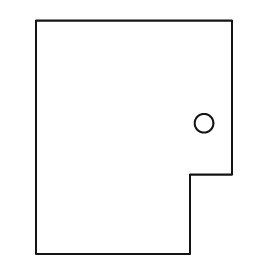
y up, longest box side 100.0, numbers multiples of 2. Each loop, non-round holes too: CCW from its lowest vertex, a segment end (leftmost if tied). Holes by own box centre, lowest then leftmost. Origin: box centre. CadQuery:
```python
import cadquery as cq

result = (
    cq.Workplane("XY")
    .moveTo(-42.0, -50.0)
    .lineTo(24.0, -50.0)
    .lineTo(24.0, -16.0)
    .lineTo(42.0, -16.0)
    .lineTo(42.0, 50.0)
    .lineTo(-42.0, 50.0)
    .close()
    .moveTo(30.0, 6.0)
    .circle(4.0)
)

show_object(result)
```